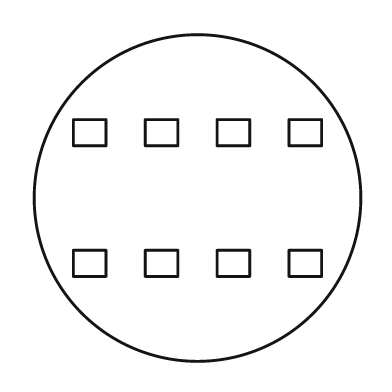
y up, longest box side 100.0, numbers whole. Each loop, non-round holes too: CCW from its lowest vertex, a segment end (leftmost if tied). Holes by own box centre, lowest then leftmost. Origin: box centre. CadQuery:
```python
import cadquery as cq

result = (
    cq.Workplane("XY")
    .moveTo(0.0, 0.0)
    .circle(50.0)
    .moveTo(-38.0, -24.0)
    .lineTo(-28.0, -24.0)
    .lineTo(-28.0, -16.0)
    .lineTo(-38.0, -16.0)
    .close()
    .moveTo(-16.0, -24.0)
    .lineTo(-6.0, -24.0)
    .lineTo(-6.0, -16.0)
    .lineTo(-16.0, -16.0)
    .close()
    .moveTo(6.0, -24.0)
    .lineTo(16.0, -24.0)
    .lineTo(16.0, -16.0)
    .lineTo(6.0, -16.0)
    .close()
    .moveTo(28.0, -24.0)
    .lineTo(38.0, -24.0)
    .lineTo(38.0, -16.0)
    .lineTo(28.0, -16.0)
    .close()
    .moveTo(-38.0, 16.0)
    .lineTo(-28.0, 16.0)
    .lineTo(-28.0, 24.0)
    .lineTo(-38.0, 24.0)
    .close()
    .moveTo(-16.0, 16.0)
    .lineTo(-6.0, 16.0)
    .lineTo(-6.0, 24.0)
    .lineTo(-16.0, 24.0)
    .close()
    .moveTo(6.0, 16.0)
    .lineTo(16.0, 16.0)
    .lineTo(16.0, 24.0)
    .lineTo(6.0, 24.0)
    .close()
    .moveTo(28.0, 16.0)
    .lineTo(38.0, 16.0)
    .lineTo(38.0, 24.0)
    .lineTo(28.0, 24.0)
    .close()
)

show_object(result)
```